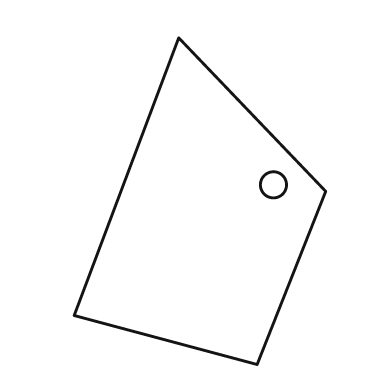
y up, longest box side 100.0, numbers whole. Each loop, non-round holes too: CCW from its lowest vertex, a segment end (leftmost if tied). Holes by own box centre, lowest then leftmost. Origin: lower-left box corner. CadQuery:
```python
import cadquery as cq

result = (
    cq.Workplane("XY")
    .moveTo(56.0, 0.0)
    .lineTo(77.0, 53.0)
    .lineTo(32.0, 100.0)
    .lineTo(0.0, 15.0)
    .close()
    .moveTo(61.0, 55.0)
    .circle(4.0)
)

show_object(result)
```